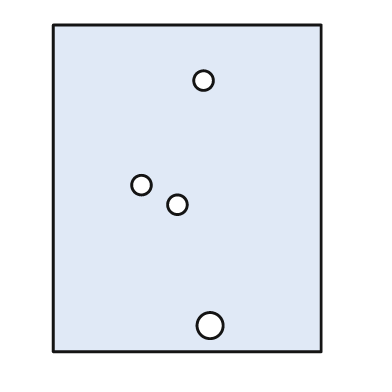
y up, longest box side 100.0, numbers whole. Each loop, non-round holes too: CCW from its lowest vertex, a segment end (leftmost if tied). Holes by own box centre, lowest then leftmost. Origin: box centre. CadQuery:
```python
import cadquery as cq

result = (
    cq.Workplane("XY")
    .moveTo(-41.0, -50.0)
    .lineTo(41.0, -50.0)
    .lineTo(41.0, 50.0)
    .lineTo(-41.0, 50.0)
    .close()
    .moveTo(7.0, -42.0)
    .circle(4.0)
    .moveTo(-3.0, -5.0)
    .circle(3.0)
    .moveTo(-14.0, 1.0)
    .circle(3.0)
    .moveTo(5.0, 33.0)
    .circle(3.0)
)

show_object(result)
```